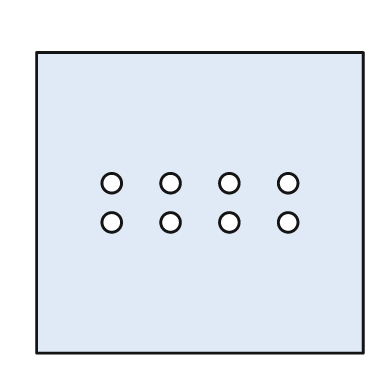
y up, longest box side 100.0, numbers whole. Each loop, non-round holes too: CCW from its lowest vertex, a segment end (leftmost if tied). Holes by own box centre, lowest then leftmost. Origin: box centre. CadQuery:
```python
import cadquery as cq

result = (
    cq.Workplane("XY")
    .moveTo(-50.0, -46.0)
    .lineTo(50.0, -46.0)
    .lineTo(50.0, 46.0)
    .lineTo(-50.0, 46.0)
    .close()
    .moveTo(-27.0, -6.0)
    .circle(3.0)
    .moveTo(-9.0, -6.0)
    .circle(3.0)
    .moveTo(9.0, -6.0)
    .circle(3.0)
    .moveTo(27.0, -6.0)
    .circle(3.0)
    .moveTo(-27.0, 6.0)
    .circle(3.0)
    .moveTo(-9.0, 6.0)
    .circle(3.0)
    .moveTo(9.0, 6.0)
    .circle(3.0)
    .moveTo(27.0, 6.0)
    .circle(3.0)
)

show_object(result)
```